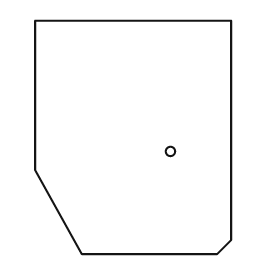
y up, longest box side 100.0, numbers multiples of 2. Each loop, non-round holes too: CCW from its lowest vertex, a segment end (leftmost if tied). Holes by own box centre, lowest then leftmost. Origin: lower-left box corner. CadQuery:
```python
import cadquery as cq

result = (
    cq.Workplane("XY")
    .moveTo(20.0, 0.0)
    .lineTo(78.0, 0.0)
    .lineTo(84.0, 6.0)
    .lineTo(84.0, 100.0)
    .lineTo(0.0, 100.0)
    .lineTo(0.0, 36.0)
    .close()
    .moveTo(58.0, 44.0)
    .circle(2.0)
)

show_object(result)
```